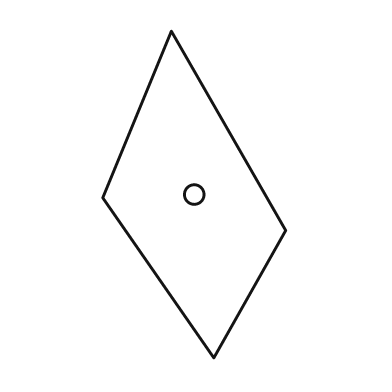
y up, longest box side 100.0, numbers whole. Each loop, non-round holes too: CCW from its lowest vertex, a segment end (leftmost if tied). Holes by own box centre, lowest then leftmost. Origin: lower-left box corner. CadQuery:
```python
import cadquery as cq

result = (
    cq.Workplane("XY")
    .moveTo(34.0, 0.0)
    .lineTo(56.0, 39.0)
    .lineTo(21.0, 100.0)
    .lineTo(0.0, 49.0)
    .close()
    .moveTo(28.0, 50.0)
    .circle(3.0)
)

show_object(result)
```